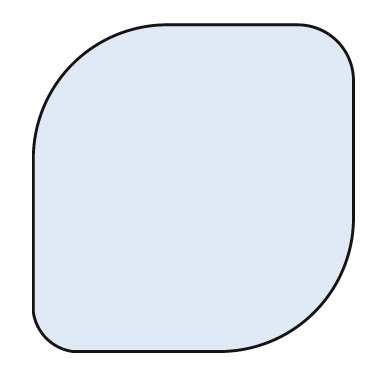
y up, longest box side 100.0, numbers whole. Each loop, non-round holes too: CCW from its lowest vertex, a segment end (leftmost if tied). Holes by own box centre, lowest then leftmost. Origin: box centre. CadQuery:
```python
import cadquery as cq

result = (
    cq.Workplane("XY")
    .moveTo(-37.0, -50.0)
    .lineTo(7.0, -50.0)
    .threePointArc((37.0, -38.0), (49.0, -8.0))
    .lineTo(49.0, 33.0)
    .threePointArc((44.0, 45.0), (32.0, 50.0))
    .lineTo(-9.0, 50.0)
    .threePointArc((-37.0, 38.0), (-49.0, 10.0))
    .lineTo(-49.0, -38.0)
    .threePointArc((-45.0, -46.0), (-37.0, -50.0))
    .close()
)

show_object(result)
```